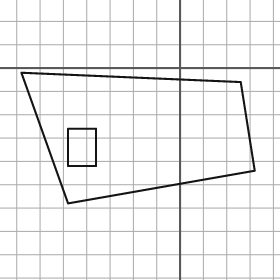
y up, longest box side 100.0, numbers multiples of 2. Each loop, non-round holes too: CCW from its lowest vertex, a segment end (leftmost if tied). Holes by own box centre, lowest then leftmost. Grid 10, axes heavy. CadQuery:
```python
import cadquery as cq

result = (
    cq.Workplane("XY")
    .moveTo(-48.0, -58.0)
    .lineTo(32.0, -44.0)
    .lineTo(26.0, -6.0)
    .lineTo(-68.0, -2.0)
    .close()
    .moveTo(-48.0, -42.0)
    .lineTo(-36.0, -42.0)
    .lineTo(-36.0, -26.0)
    .lineTo(-48.0, -26.0)
    .close()
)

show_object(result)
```